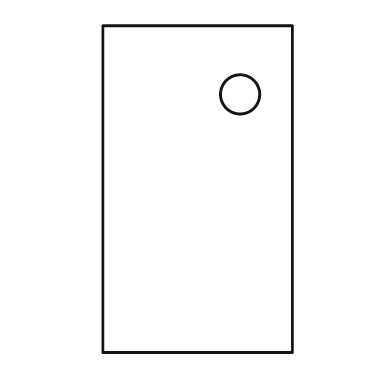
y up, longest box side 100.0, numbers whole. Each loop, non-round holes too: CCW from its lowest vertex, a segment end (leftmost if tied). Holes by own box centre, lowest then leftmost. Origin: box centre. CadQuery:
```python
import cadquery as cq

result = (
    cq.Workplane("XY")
    .moveTo(-29.0, -50.0)
    .lineTo(29.0, -50.0)
    .lineTo(29.0, 50.0)
    .lineTo(-29.0, 50.0)
    .close()
    .moveTo(13.0, 29.0)
    .circle(6.0)
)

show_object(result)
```